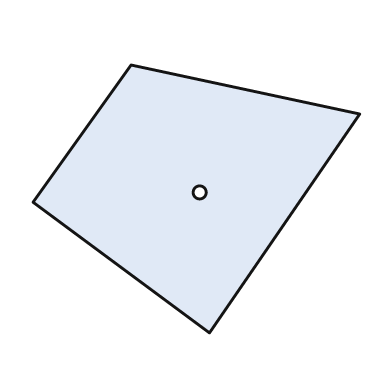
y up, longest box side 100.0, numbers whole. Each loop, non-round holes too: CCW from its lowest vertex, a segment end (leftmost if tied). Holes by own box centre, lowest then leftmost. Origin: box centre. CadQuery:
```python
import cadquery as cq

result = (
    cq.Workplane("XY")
    .moveTo(4.0, -41.0)
    .lineTo(50.0, 26.0)
    .lineTo(-20.0, 41.0)
    .lineTo(-50.0, -1.0)
    .close()
    .moveTo(1.0, 2.0)
    .circle(2.0)
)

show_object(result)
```